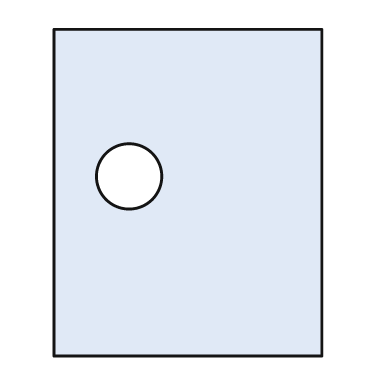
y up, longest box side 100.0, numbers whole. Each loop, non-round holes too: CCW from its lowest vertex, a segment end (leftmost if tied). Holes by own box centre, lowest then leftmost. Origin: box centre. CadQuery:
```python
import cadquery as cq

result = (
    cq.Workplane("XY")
    .moveTo(-41.0, -50.0)
    .lineTo(41.0, -50.0)
    .lineTo(41.0, 50.0)
    .lineTo(-41.0, 50.0)
    .close()
    .moveTo(-18.0, 5.0)
    .circle(10.0)
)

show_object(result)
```